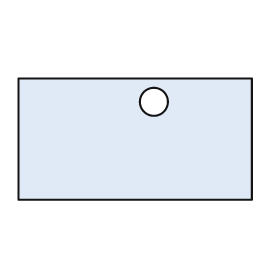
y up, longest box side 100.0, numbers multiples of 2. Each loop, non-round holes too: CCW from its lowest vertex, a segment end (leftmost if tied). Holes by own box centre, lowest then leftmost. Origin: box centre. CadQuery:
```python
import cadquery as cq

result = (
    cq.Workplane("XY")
    .moveTo(-50.0, -26.0)
    .lineTo(50.0, -26.0)
    .lineTo(50.0, 26.0)
    .lineTo(-50.0, 26.0)
    .close()
    .moveTo(8.0, 16.0)
    .circle(6.0)
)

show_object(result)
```